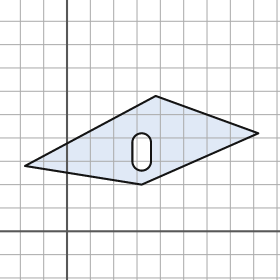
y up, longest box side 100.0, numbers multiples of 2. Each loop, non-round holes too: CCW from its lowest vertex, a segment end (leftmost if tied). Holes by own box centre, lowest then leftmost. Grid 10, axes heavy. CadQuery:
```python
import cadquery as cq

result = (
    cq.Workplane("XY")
    .moveTo(32.0, 20.0)
    .lineTo(82.0, 42.0)
    .lineTo(38.0, 58.0)
    .lineTo(-18.0, 28.0)
    .close()
    .moveTo(28.0, 30.0)
    .threePointArc((32.0, 26.0), (36.0, 30.0))
    .lineTo(36.0, 38.0)
    .threePointArc((32.0, 42.0), (28.0, 38.0))
    .close()
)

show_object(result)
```